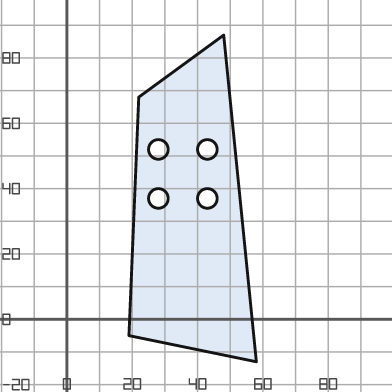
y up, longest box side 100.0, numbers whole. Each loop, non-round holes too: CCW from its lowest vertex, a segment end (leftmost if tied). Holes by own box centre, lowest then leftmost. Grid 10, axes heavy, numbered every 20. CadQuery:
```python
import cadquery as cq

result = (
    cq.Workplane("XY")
    .moveTo(58.0, -13.0)
    .lineTo(48.0, 87.0)
    .lineTo(22.0, 68.0)
    .lineTo(19.0, -5.0)
    .close()
    .moveTo(28.0, 37.0)
    .circle(3.0)
    .moveTo(43.0, 37.0)
    .circle(3.0)
    .moveTo(28.0, 52.0)
    .circle(3.0)
    .moveTo(43.0, 52.0)
    .circle(3.0)
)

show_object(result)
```